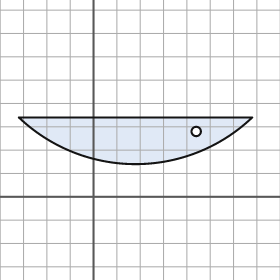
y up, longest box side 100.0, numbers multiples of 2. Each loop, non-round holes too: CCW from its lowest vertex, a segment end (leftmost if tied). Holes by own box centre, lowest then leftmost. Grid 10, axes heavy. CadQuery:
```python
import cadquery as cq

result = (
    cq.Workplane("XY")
    .moveTo(-32.0, 34.0)
    .threePointArc((18.0, 14.0), (68.0, 34.0))
    .close()
    .moveTo(44.0, 28.0)
    .circle(2.0)
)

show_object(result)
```